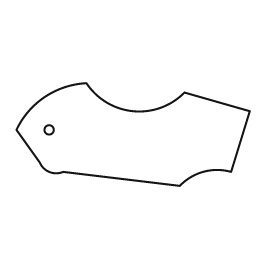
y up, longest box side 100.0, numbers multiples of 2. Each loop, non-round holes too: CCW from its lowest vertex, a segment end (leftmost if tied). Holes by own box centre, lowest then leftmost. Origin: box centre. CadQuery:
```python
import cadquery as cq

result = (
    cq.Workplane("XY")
    .moveTo(20.0, -22.0)
    .threePointArc((30.0, -16.0), (42.0, -16.0))
    .lineTo(50.0, 10.0)
    .lineTo(22.0, 18.0)
    .threePointArc((0.0, 10.0), (-20.0, 22.0))
    .threePointArc((-38.0, 16.0), (-50.0, 2.0))
    .lineTo(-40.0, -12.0)
    .threePointArc((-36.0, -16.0), (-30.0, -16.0))
    .close()
    .moveTo(-36.0, 2.0)
    .circle(2.0)
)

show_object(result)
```